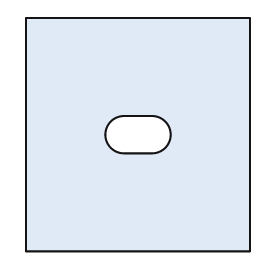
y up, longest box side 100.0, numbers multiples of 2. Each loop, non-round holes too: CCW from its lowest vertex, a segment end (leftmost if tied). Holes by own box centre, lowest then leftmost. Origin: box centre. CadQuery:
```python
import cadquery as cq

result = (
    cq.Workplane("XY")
    .moveTo(-48.0, -50.0)
    .lineTo(48.0, -50.0)
    .lineTo(48.0, 50.0)
    .lineTo(-48.0, 50.0)
    .close()
    .moveTo(-6.0, -8.0)
    .lineTo(6.0, -8.0)
    .threePointArc((14.0, 0.0), (6.0, 8.0))
    .lineTo(-6.0, 8.0)
    .threePointArc((-14.0, 0.0), (-6.0, -8.0))
    .close()
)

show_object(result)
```